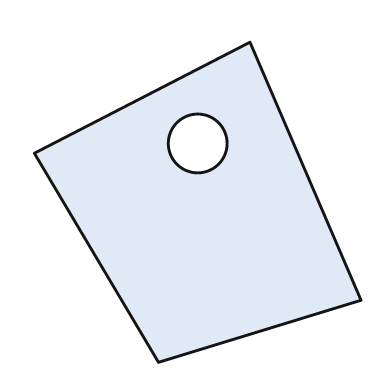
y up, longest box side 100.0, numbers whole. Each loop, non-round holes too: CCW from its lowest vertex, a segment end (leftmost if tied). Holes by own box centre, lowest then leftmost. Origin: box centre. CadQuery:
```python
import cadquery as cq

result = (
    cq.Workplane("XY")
    .moveTo(-12.0, -49.0)
    .lineTo(50.0, -30.0)
    .lineTo(16.0, 49.0)
    .lineTo(-50.0, 15.0)
    .close()
    .moveTo(0.0, 18.0)
    .circle(9.0)
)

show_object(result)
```